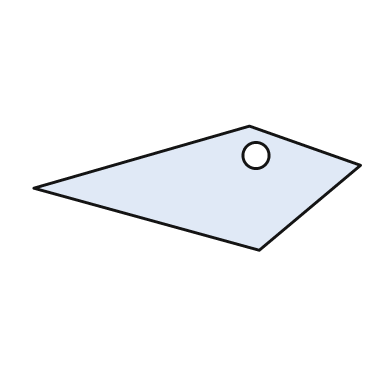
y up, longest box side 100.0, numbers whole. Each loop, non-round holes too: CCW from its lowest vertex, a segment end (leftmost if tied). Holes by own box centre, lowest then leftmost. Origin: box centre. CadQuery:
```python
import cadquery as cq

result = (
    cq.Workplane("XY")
    .moveTo(19.0, -19.0)
    .lineTo(50.0, 7.0)
    .lineTo(16.0, 19.0)
    .lineTo(-50.0, 0.0)
    .close()
    .moveTo(18.0, 10.0)
    .circle(4.0)
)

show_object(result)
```